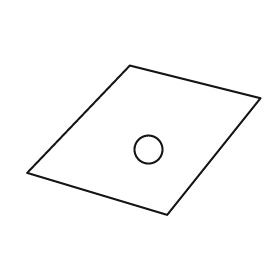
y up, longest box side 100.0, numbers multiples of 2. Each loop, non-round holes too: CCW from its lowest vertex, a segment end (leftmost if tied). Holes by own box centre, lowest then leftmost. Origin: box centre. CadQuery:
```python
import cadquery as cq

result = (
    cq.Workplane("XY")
    .moveTo(10.0, -32.0)
    .lineTo(50.0, 18.0)
    .lineTo(-6.0, 32.0)
    .lineTo(-50.0, -14.0)
    .close()
    .moveTo(2.0, -4.0)
    .circle(6.0)
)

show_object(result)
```